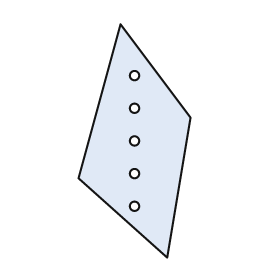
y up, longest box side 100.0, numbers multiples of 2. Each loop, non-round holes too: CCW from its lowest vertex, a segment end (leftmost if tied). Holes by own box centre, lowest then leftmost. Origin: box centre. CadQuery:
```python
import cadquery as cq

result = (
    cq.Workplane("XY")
    .moveTo(14.0, -50.0)
    .lineTo(24.0, 10.0)
    .lineTo(-6.0, 50.0)
    .lineTo(-24.0, -16.0)
    .close()
    .moveTo(0.0, -28.0)
    .circle(2.0)
    .moveTo(0.0, -14.0)
    .circle(2.0)
    .moveTo(0.0, 0.0)
    .circle(2.0)
    .moveTo(0.0, 14.0)
    .circle(2.0)
    .moveTo(0.0, 28.0)
    .circle(2.0)
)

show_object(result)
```